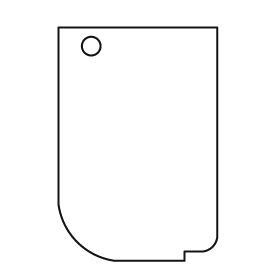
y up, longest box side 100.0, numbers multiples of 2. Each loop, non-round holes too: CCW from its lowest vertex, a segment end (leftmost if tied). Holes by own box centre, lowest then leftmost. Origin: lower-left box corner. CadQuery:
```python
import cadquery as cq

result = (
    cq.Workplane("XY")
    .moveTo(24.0, 0.0)
    .lineTo(54.0, 0.0)
    .lineTo(54.0, 4.0)
    .lineTo(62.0, 4.0)
    .threePointArc((66.0, 6.0), (68.0, 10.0))
    .lineTo(68.0, 100.0)
    .lineTo(0.0, 100.0)
    .lineTo(0.0, 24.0)
    .threePointArc((8.0, 8.0), (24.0, 0.0))
    .close()
    .moveTo(14.0, 92.0)
    .circle(4.0)
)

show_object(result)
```